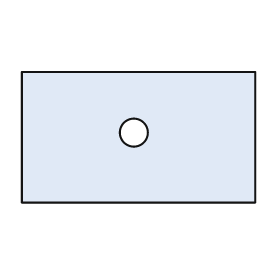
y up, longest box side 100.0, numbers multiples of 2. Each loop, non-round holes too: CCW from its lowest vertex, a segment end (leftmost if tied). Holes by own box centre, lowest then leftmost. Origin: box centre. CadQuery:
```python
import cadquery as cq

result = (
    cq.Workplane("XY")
    .moveTo(-50.0, -28.0)
    .lineTo(50.0, -28.0)
    .lineTo(50.0, 28.0)
    .lineTo(-50.0, 28.0)
    .close()
    .moveTo(-2.0, 2.0)
    .circle(6.0)
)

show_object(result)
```